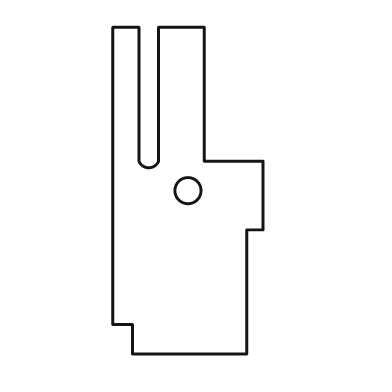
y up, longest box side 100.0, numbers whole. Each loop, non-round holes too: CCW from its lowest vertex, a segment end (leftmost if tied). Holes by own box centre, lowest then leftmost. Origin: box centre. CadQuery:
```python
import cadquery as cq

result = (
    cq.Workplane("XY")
    .moveTo(-17.0, -50.0)
    .lineTo(18.0, -50.0)
    .lineTo(18.0, -12.0)
    .lineTo(23.0, -12.0)
    .lineTo(23.0, 9.0)
    .lineTo(5.0, 9.0)
    .lineTo(5.0, 50.0)
    .lineTo(-9.0, 50.0)
    .lineTo(-9.0, 9.0)
    .threePointArc((-12.0, 7.0), (-15.0, 9.0))
    .lineTo(-15.0, 50.0)
    .lineTo(-23.0, 50.0)
    .lineTo(-23.0, -41.0)
    .lineTo(-17.0, -41.0)
    .close()
    .moveTo(0.0, 0.0)
    .circle(4.0)
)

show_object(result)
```